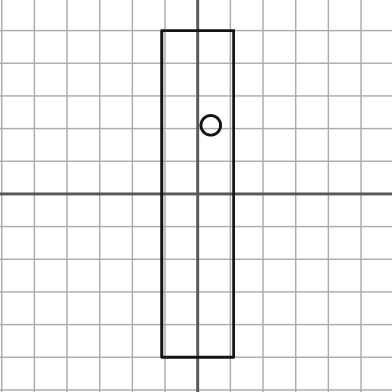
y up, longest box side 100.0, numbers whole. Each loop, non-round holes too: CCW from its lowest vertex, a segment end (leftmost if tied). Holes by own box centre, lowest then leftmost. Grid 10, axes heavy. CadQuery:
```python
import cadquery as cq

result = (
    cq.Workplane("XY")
    .moveTo(-11.0, -50.0)
    .lineTo(11.0, -50.0)
    .lineTo(11.0, 50.0)
    .lineTo(-11.0, 50.0)
    .close()
    .moveTo(4.0, 21.0)
    .circle(3.0)
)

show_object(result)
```